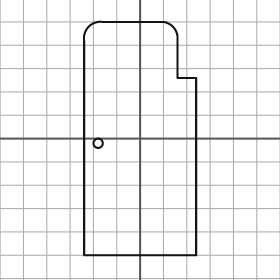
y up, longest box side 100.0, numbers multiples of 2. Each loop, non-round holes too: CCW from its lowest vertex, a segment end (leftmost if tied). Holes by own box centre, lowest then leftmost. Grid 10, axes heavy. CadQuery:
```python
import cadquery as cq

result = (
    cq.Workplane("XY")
    .moveTo(-24.0, -50.0)
    .lineTo(24.0, -50.0)
    .lineTo(24.0, 26.0)
    .lineTo(16.0, 26.0)
    .lineTo(16.0, 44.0)
    .threePointArc((14.0, 48.0), (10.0, 50.0))
    .lineTo(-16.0, 50.0)
    .threePointArc((-22.0, 48.0), (-24.0, 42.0))
    .close()
    .moveTo(-18.0, -2.0)
    .circle(2.0)
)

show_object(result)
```